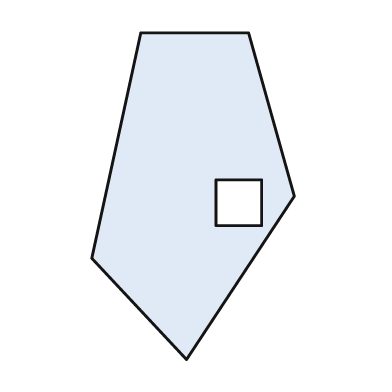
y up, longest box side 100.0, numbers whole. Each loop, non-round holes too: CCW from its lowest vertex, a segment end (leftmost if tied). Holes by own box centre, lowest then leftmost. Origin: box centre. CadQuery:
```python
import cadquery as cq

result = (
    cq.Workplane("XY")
    .moveTo(-2.0, -50.0)
    .lineTo(31.0, 0.0)
    .lineTo(17.0, 50.0)
    .lineTo(-16.0, 50.0)
    .lineTo(-31.0, -19.0)
    .close()
    .moveTo(7.0, -9.0)
    .lineTo(21.0, -9.0)
    .lineTo(21.0, 5.0)
    .lineTo(7.0, 5.0)
    .close()
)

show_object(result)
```